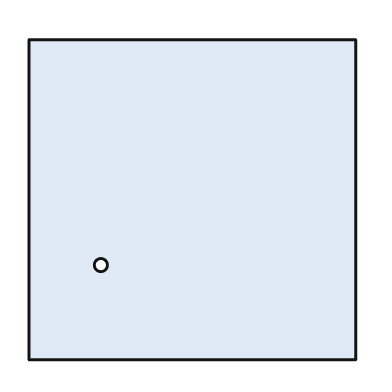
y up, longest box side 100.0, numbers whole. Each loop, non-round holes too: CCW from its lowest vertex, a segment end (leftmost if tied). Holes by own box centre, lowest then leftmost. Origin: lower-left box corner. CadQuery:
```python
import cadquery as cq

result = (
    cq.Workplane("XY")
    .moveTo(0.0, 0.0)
    .lineTo(100.0, 0.0)
    .lineTo(100.0, 98.0)
    .lineTo(0.0, 98.0)
    .close()
    .moveTo(22.0, 29.0)
    .circle(2.0)
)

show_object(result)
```